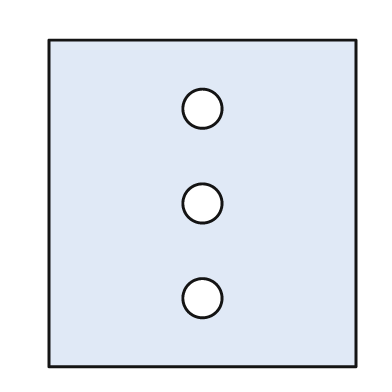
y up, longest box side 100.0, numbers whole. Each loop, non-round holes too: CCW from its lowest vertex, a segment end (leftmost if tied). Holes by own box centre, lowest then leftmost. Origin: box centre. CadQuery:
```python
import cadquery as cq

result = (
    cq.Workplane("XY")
    .moveTo(-47.0, -50.0)
    .lineTo(47.0, -50.0)
    .lineTo(47.0, 50.0)
    .lineTo(-47.0, 50.0)
    .close()
    .moveTo(0.0, -29.0)
    .circle(6.0)
    .moveTo(0.0, 0.0)
    .circle(6.0)
    .moveTo(0.0, 29.0)
    .circle(6.0)
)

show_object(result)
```